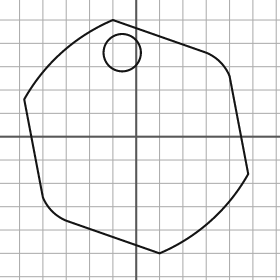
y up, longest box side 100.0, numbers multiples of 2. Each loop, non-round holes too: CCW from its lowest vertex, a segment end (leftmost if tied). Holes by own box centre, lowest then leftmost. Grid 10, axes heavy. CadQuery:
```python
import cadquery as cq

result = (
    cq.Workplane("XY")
    .moveTo(10.0, -50.0)
    .threePointArc((32.0, -36.0), (48.0, -16.0))
    .lineTo(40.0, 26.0)
    .threePointArc((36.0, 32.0), (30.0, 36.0))
    .lineTo(-10.0, 50.0)
    .threePointArc((-32.0, 36.0), (-48.0, 16.0))
    .lineTo(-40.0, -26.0)
    .threePointArc((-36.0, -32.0), (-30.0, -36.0))
    .close()
    .moveTo(-6.0, 36.0)
    .circle(8.0)
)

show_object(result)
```